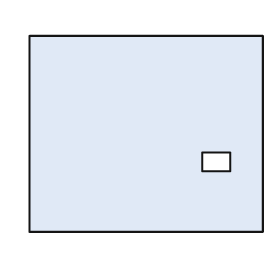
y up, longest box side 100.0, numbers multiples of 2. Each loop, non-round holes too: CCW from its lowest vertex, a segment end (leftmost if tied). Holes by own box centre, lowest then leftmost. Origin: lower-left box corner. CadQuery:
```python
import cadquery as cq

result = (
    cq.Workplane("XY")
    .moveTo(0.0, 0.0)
    .lineTo(100.0, 0.0)
    .lineTo(100.0, 84.0)
    .lineTo(0.0, 84.0)
    .close()
    .moveTo(74.0, 26.0)
    .lineTo(86.0, 26.0)
    .lineTo(86.0, 34.0)
    .lineTo(74.0, 34.0)
    .close()
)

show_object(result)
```